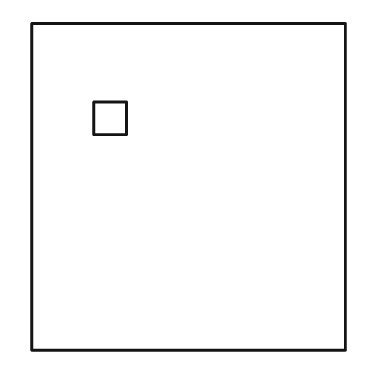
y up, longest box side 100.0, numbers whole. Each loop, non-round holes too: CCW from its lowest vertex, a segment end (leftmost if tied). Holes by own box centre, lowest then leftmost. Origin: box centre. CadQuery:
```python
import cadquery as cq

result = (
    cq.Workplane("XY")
    .moveTo(-48.0, -50.0)
    .lineTo(48.0, -50.0)
    .lineTo(48.0, 50.0)
    .lineTo(-48.0, 50.0)
    .close()
    .moveTo(-29.0, 16.0)
    .lineTo(-19.0, 16.0)
    .lineTo(-19.0, 26.0)
    .lineTo(-29.0, 26.0)
    .close()
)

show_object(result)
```